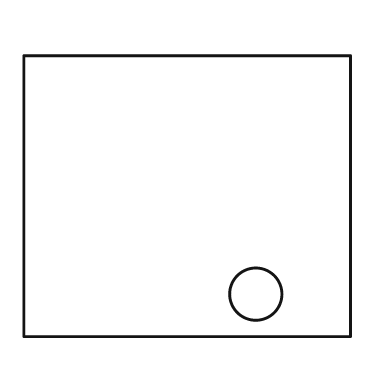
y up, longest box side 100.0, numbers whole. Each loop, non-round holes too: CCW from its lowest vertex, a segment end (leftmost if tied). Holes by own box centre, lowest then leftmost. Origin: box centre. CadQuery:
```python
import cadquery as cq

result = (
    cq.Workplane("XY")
    .moveTo(-50.0, -43.0)
    .lineTo(50.0, -43.0)
    .lineTo(50.0, 43.0)
    .lineTo(-50.0, 43.0)
    .close()
    .moveTo(21.0, -30.0)
    .circle(8.0)
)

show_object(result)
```